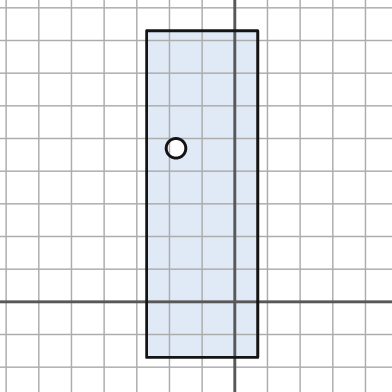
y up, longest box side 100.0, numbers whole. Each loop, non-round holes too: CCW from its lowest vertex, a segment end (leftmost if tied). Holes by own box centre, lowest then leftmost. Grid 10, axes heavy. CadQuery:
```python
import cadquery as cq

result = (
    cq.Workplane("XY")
    .moveTo(-27.0, -17.0)
    .lineTo(7.0, -17.0)
    .lineTo(7.0, 83.0)
    .lineTo(-27.0, 83.0)
    .close()
    .moveTo(-18.0, 47.0)
    .circle(3.0)
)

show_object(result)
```